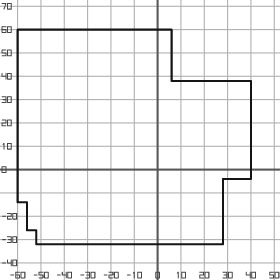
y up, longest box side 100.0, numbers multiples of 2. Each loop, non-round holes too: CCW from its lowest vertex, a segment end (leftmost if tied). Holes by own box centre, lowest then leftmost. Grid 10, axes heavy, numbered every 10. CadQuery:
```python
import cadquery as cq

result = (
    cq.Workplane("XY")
    .moveTo(-52.0, -32.0)
    .lineTo(28.0, -32.0)
    .lineTo(28.0, -4.0)
    .lineTo(40.0, -4.0)
    .lineTo(40.0, 38.0)
    .lineTo(6.0, 38.0)
    .lineTo(6.0, 60.0)
    .lineTo(-60.0, 60.0)
    .lineTo(-60.0, -14.0)
    .lineTo(-56.0, -14.0)
    .lineTo(-56.0, -26.0)
    .lineTo(-52.0, -26.0)
    .close()
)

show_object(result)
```